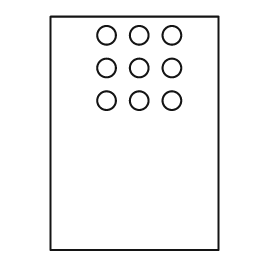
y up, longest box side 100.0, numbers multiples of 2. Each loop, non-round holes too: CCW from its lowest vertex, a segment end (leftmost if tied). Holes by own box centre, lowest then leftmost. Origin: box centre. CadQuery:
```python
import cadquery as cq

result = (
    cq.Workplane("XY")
    .moveTo(-36.0, -50.0)
    .lineTo(36.0, -50.0)
    .lineTo(36.0, 50.0)
    .lineTo(-36.0, 50.0)
    .close()
    .moveTo(-12.0, 14.0)
    .circle(4.0)
    .moveTo(2.0, 14.0)
    .circle(4.0)
    .moveTo(16.0, 14.0)
    .circle(4.0)
    .moveTo(-12.0, 28.0)
    .circle(4.0)
    .moveTo(2.0, 28.0)
    .circle(4.0)
    .moveTo(16.0, 28.0)
    .circle(4.0)
    .moveTo(-12.0, 42.0)
    .circle(4.0)
    .moveTo(2.0, 42.0)
    .circle(4.0)
    .moveTo(16.0, 42.0)
    .circle(4.0)
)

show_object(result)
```